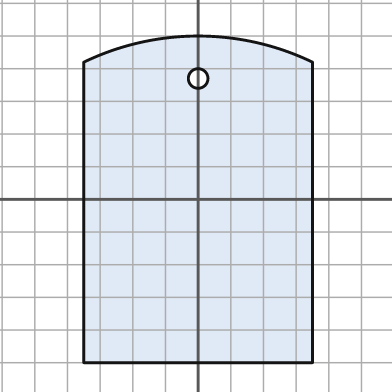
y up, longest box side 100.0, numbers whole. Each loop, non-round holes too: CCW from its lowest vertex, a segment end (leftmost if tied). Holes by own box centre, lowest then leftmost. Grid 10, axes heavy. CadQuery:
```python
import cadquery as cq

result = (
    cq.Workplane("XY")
    .moveTo(-35.0, -50.0)
    .lineTo(35.0, -50.0)
    .lineTo(35.0, 42.0)
    .threePointArc((0.0, 50.0), (-35.0, 42.0))
    .close()
    .moveTo(0.0, 37.0)
    .circle(3.0)
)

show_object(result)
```